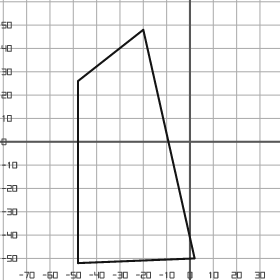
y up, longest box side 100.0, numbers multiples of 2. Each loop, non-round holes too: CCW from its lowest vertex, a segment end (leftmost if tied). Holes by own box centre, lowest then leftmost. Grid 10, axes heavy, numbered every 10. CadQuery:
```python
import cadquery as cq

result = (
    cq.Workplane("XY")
    .moveTo(-48.0, -52.0)
    .lineTo(2.0, -50.0)
    .lineTo(-20.0, 48.0)
    .lineTo(-48.0, 26.0)
    .close()
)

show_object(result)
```